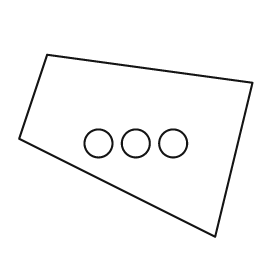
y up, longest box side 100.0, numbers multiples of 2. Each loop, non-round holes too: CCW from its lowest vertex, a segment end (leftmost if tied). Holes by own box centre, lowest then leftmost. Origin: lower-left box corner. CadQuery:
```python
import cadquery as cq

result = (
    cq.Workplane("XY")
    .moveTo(84.0, 0.0)
    .lineTo(100.0, 66.0)
    .lineTo(12.0, 78.0)
    .lineTo(0.0, 42.0)
    .close()
    .moveTo(34.0, 40.0)
    .circle(6.0)
    .moveTo(50.0, 40.0)
    .circle(6.0)
    .moveTo(66.0, 40.0)
    .circle(6.0)
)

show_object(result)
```